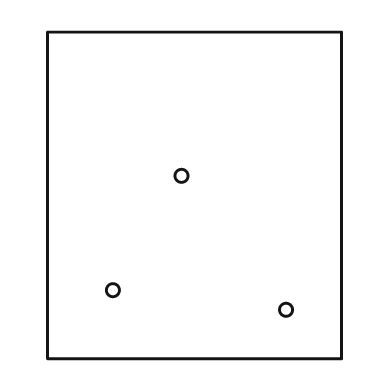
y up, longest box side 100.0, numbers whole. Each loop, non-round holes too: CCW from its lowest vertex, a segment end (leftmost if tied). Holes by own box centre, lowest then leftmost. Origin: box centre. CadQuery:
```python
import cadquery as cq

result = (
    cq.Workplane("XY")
    .moveTo(-45.0, -50.0)
    .lineTo(45.0, -50.0)
    .lineTo(45.0, 50.0)
    .lineTo(-45.0, 50.0)
    .close()
    .moveTo(28.0, -35.0)
    .circle(2.0)
    .moveTo(-25.0, -29.0)
    .circle(2.0)
    .moveTo(-4.0, 6.0)
    .circle(2.0)
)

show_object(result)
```